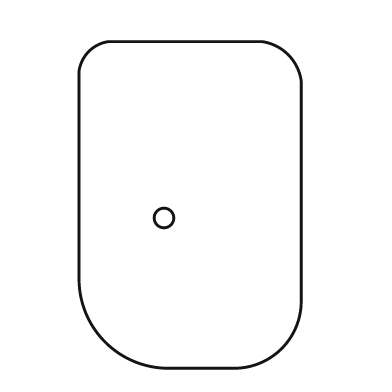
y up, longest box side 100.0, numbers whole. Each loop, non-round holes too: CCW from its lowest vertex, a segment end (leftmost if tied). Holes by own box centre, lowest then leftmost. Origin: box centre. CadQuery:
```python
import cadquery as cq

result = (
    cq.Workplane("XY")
    .moveTo(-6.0, -50.0)
    .lineTo(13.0, -50.0)
    .threePointArc((28.0, -44.0), (34.0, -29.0))
    .lineTo(34.0, 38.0)
    .threePointArc((30.0, 46.0), (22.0, 50.0))
    .lineTo(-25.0, 50.0)
    .threePointArc((-31.0, 47.0), (-34.0, 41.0))
    .lineTo(-34.0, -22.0)
    .threePointArc((-26.0, -42.0), (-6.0, -50.0))
    .close()
    .moveTo(-8.0, -4.0)
    .circle(3.0)
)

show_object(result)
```